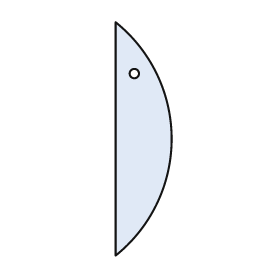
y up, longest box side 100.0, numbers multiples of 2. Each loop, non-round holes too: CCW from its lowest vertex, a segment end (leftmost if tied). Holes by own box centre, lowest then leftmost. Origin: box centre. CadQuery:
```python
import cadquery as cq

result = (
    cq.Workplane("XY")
    .moveTo(-12.0, -50.0)
    .threePointArc((12.0, 0.0), (-12.0, 50.0))
    .close()
    .moveTo(-4.0, 28.0)
    .circle(2.0)
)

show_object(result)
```